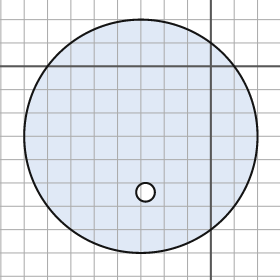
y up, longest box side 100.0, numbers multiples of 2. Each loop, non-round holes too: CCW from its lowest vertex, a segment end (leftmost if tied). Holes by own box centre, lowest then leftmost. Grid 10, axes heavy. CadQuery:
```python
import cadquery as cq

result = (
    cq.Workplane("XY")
    .moveTo(-30.0, -30.0)
    .circle(50.0)
    .moveTo(-28.0, -54.0)
    .circle(4.0)
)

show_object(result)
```